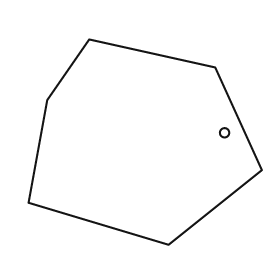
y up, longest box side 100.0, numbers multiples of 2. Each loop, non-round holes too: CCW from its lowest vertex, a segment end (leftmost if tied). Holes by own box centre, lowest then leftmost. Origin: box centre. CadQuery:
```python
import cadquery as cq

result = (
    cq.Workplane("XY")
    .moveTo(10.0, -44.0)
    .lineTo(50.0, -12.0)
    .lineTo(30.0, 32.0)
    .lineTo(-24.0, 44.0)
    .lineTo(-42.0, 18.0)
    .lineTo(-50.0, -26.0)
    .close()
    .moveTo(34.0, 4.0)
    .circle(2.0)
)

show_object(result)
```